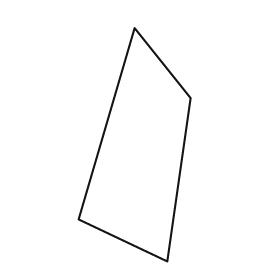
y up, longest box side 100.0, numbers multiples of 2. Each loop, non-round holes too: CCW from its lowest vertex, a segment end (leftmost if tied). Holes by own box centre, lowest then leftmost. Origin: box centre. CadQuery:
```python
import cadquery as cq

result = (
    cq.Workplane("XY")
    .moveTo(14.0, -50.0)
    .lineTo(24.0, 20.0)
    .lineTo(0.0, 50.0)
    .lineTo(-24.0, -32.0)
    .close()
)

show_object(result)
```